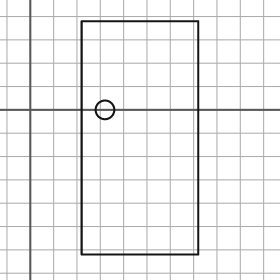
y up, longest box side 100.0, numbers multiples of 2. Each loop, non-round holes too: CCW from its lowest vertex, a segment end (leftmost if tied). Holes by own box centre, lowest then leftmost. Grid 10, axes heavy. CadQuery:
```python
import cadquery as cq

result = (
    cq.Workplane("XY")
    .moveTo(22.0, -62.0)
    .lineTo(72.0, -62.0)
    .lineTo(72.0, 38.0)
    .lineTo(22.0, 38.0)
    .close()
    .moveTo(32.0, 0.0)
    .circle(4.0)
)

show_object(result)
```